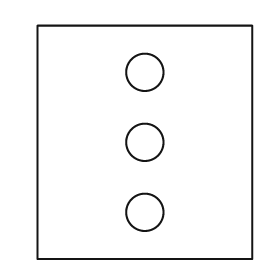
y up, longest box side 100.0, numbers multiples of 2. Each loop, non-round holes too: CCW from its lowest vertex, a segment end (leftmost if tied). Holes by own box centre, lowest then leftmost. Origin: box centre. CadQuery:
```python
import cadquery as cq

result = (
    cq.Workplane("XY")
    .moveTo(-46.0, -50.0)
    .lineTo(46.0, -50.0)
    .lineTo(46.0, 50.0)
    .lineTo(-46.0, 50.0)
    .close()
    .moveTo(0.0, -30.0)
    .circle(8.0)
    .moveTo(0.0, 0.0)
    .circle(8.0)
    .moveTo(0.0, 30.0)
    .circle(8.0)
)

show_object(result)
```